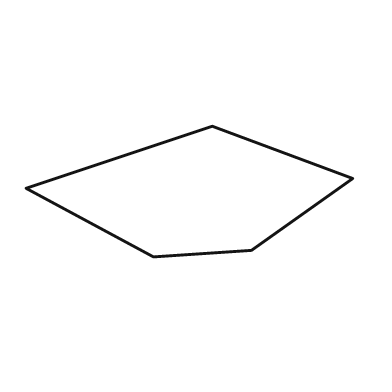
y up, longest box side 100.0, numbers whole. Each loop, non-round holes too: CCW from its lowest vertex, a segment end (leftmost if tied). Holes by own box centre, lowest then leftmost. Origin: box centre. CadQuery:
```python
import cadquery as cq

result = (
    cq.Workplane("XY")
    .moveTo(-11.0, -20.0)
    .lineTo(19.0, -18.0)
    .lineTo(50.0, 4.0)
    .lineTo(7.0, 20.0)
    .lineTo(-50.0, 1.0)
    .close()
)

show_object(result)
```